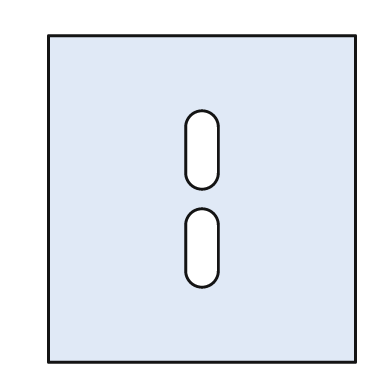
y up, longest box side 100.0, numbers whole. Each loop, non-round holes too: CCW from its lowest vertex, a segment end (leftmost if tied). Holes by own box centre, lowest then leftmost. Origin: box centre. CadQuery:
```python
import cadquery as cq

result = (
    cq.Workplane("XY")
    .moveTo(-47.0, -50.0)
    .lineTo(47.0, -50.0)
    .lineTo(47.0, 50.0)
    .lineTo(-47.0, 50.0)
    .close()
    .moveTo(-5.0, -22.0)
    .threePointArc((0.0, -27.0), (5.0, -22.0))
    .lineTo(5.0, -8.0)
    .threePointArc((0.0, -3.0), (-5.0, -8.0))
    .close()
    .moveTo(-5.0, 8.0)
    .threePointArc((0.0, 3.0), (5.0, 8.0))
    .lineTo(5.0, 22.0)
    .threePointArc((0.0, 27.0), (-5.0, 22.0))
    .close()
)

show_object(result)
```